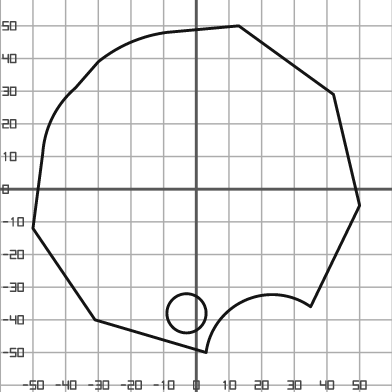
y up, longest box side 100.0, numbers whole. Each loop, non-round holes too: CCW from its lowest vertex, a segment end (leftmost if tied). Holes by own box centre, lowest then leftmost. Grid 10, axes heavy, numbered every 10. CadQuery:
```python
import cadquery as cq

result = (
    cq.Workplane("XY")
    .moveTo(3.0, -50.0)
    .threePointArc((15.0, -34.0), (35.0, -36.0))
    .lineTo(50.0, -5.0)
    .lineTo(42.0, 29.0)
    .lineTo(13.0, 50.0)
    .lineTo(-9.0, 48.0)
    .threePointArc((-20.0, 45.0), (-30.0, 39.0))
    .lineTo(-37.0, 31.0)
    .threePointArc((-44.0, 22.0), (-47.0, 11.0))
    .lineTo(-50.0, -12.0)
    .lineTo(-31.0, -40.0)
    .close()
    .moveTo(-3.0, -38.0)
    .circle(6.0)
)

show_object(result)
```